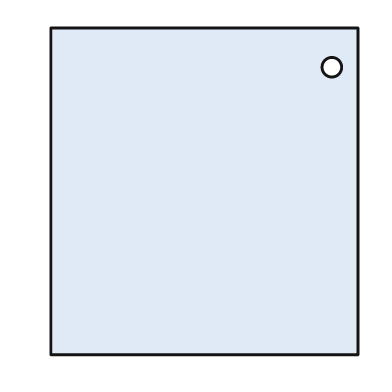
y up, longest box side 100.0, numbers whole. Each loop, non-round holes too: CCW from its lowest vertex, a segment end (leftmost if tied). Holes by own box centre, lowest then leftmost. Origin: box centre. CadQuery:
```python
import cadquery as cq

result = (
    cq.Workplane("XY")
    .moveTo(-47.0, -50.0)
    .lineTo(47.0, -50.0)
    .lineTo(47.0, 50.0)
    .lineTo(-47.0, 50.0)
    .close()
    .moveTo(39.0, 38.0)
    .circle(3.0)
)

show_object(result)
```